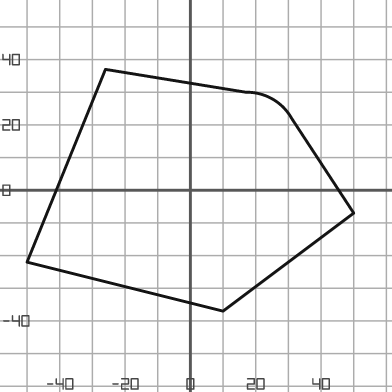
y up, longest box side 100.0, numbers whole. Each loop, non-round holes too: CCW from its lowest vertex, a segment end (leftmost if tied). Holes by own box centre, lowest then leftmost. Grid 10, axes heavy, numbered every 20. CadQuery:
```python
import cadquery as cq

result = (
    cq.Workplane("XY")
    .moveTo(10.0, -37.0)
    .lineTo(50.0, -7.0)
    .lineTo(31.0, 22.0)
    .threePointArc((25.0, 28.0), (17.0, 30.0))
    .lineTo(-26.0, 37.0)
    .lineTo(-50.0, -22.0)
    .close()
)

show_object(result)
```